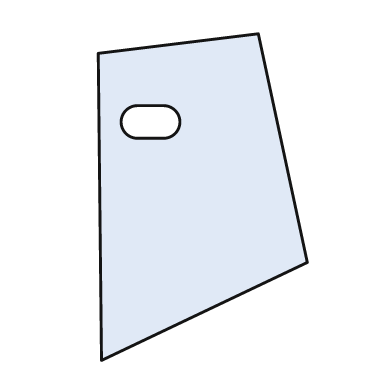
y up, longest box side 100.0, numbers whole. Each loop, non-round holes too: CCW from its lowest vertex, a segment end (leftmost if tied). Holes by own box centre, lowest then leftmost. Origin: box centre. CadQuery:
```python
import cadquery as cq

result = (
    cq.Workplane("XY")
    .moveTo(-31.0, -50.0)
    .lineTo(32.0, -20.0)
    .lineTo(17.0, 50.0)
    .lineTo(-32.0, 44.0)
    .close()
    .moveTo(-20.0, 18.0)
    .lineTo(-12.0, 18.0)
    .threePointArc((-7.0, 23.0), (-12.0, 28.0))
    .lineTo(-20.0, 28.0)
    .threePointArc((-25.0, 23.0), (-20.0, 18.0))
    .close()
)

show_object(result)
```